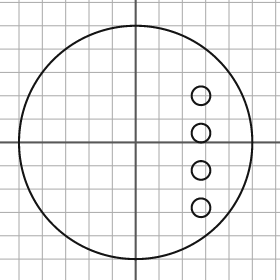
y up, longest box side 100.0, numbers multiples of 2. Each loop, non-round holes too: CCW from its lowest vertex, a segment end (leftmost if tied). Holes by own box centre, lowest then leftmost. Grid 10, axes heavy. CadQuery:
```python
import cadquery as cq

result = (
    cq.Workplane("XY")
    .moveTo(0.0, 0.0)
    .circle(50.0)
    .moveTo(28.0, -28.0)
    .circle(4.0)
    .moveTo(28.0, -12.0)
    .circle(4.0)
    .moveTo(28.0, 4.0)
    .circle(4.0)
    .moveTo(28.0, 20.0)
    .circle(4.0)
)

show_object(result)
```